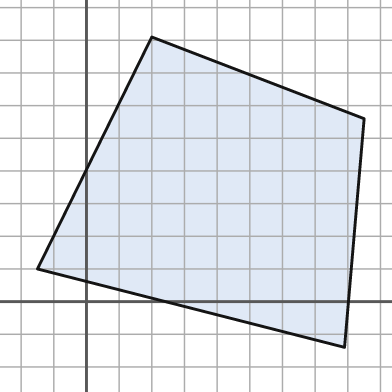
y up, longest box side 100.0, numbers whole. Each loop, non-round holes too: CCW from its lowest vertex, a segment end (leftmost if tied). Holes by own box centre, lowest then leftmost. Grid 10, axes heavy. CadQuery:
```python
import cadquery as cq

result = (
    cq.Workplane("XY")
    .moveTo(79.0, -14.0)
    .lineTo(85.0, 56.0)
    .lineTo(20.0, 81.0)
    .lineTo(-15.0, 10.0)
    .close()
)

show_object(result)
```